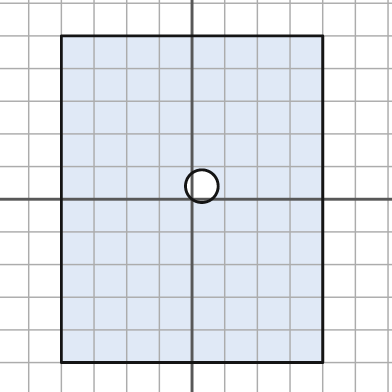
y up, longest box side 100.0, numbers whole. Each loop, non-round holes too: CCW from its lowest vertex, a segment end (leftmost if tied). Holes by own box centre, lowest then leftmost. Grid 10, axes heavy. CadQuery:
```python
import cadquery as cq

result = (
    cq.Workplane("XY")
    .moveTo(-40.0, -50.0)
    .lineTo(40.0, -50.0)
    .lineTo(40.0, 50.0)
    .lineTo(-40.0, 50.0)
    .close()
    .moveTo(3.0, 4.0)
    .circle(5.0)
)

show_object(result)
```